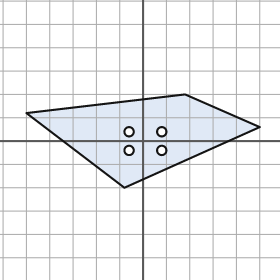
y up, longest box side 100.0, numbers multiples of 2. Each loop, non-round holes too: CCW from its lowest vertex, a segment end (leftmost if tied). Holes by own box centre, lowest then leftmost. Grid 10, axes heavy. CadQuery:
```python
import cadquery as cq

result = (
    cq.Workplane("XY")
    .moveTo(-8.0, -20.0)
    .lineTo(50.0, 6.0)
    .lineTo(18.0, 20.0)
    .lineTo(-50.0, 12.0)
    .close()
    .moveTo(-6.0, -4.0)
    .circle(2.0)
    .moveTo(8.0, -4.0)
    .circle(2.0)
    .moveTo(-6.0, 4.0)
    .circle(2.0)
    .moveTo(8.0, 4.0)
    .circle(2.0)
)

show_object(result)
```